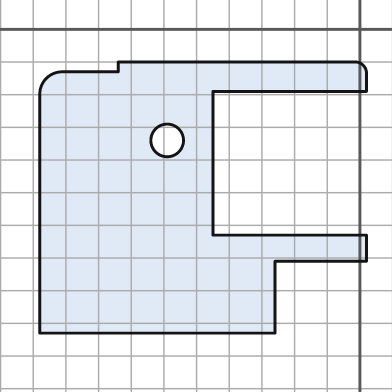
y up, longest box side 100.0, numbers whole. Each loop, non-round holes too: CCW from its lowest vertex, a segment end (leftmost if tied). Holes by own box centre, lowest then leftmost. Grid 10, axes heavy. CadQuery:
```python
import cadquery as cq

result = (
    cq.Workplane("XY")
    .moveTo(-98.0, -93.0)
    .lineTo(-26.0, -93.0)
    .lineTo(-26.0, -71.0)
    .lineTo(2.0, -71.0)
    .lineTo(2.0, -63.0)
    .lineTo(-45.0, -63.0)
    .lineTo(-45.0, -19.0)
    .lineTo(2.0, -19.0)
    .lineTo(2.0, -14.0)
    .threePointArc((1.0, -11.0), (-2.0, -10.0))
    .lineTo(-74.0, -10.0)
    .lineTo(-74.0, -13.0)
    .lineTo(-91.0, -13.0)
    .threePointArc((-96.0, -15.0), (-98.0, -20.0))
    .close()
    .moveTo(-59.0, -34.0)
    .circle(5.0)
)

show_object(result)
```